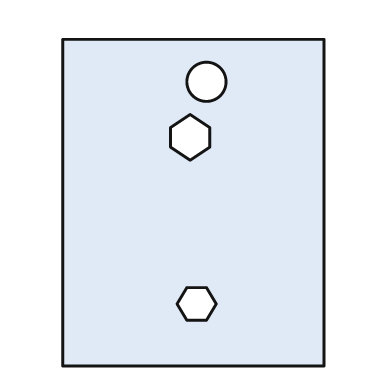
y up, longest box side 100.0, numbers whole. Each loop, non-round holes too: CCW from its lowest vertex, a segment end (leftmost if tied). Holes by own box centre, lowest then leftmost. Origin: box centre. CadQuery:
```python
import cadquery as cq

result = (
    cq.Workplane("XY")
    .moveTo(-40.0, -50.0)
    .lineTo(40.0, -50.0)
    .lineTo(40.0, 50.0)
    .lineTo(-40.0, 50.0)
    .close()
    .moveTo(-2.0, -36.0)
    .lineTo(4.0, -36.0)
    .lineTo(7.0, -31.0)
    .lineTo(4.0, -26.0)
    .lineTo(-2.0, -26.0)
    .lineTo(-5.0, -31.0)
    .close()
    .moveTo(-1.0, 13.0)
    .lineTo(5.0, 17.0)
    .lineTo(5.0, 23.0)
    .lineTo(-1.0, 27.0)
    .lineTo(-7.0, 23.0)
    .lineTo(-7.0, 17.0)
    .close()
    .moveTo(4.0, 37.0)
    .circle(6.0)
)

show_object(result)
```